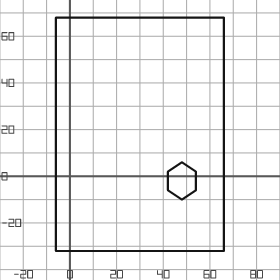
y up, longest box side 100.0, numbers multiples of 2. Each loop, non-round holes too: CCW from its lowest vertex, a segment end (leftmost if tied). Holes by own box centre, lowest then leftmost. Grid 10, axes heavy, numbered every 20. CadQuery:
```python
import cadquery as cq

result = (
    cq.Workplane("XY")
    .moveTo(-6.0, -32.0)
    .lineTo(66.0, -32.0)
    .lineTo(66.0, 68.0)
    .lineTo(-6.0, 68.0)
    .close()
    .moveTo(48.0, -10.0)
    .lineTo(54.0, -6.0)
    .lineTo(54.0, 2.0)
    .lineTo(48.0, 6.0)
    .lineTo(42.0, 2.0)
    .lineTo(42.0, -6.0)
    .close()
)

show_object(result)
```